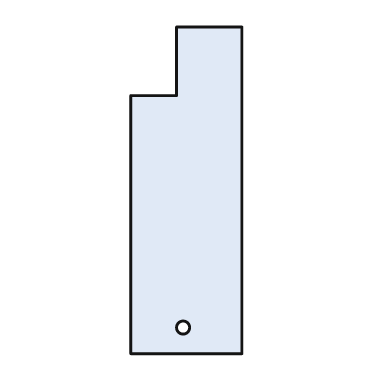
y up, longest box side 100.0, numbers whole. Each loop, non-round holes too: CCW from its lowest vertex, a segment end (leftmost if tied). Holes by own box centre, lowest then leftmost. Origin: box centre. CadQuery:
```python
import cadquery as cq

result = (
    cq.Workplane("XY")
    .moveTo(-17.0, -50.0)
    .lineTo(17.0, -50.0)
    .lineTo(17.0, 50.0)
    .lineTo(-3.0, 50.0)
    .lineTo(-3.0, 29.0)
    .lineTo(-17.0, 29.0)
    .close()
    .moveTo(-1.0, -42.0)
    .circle(2.0)
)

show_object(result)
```